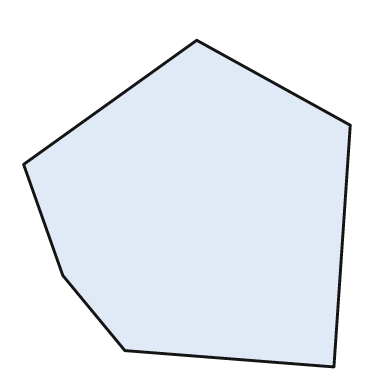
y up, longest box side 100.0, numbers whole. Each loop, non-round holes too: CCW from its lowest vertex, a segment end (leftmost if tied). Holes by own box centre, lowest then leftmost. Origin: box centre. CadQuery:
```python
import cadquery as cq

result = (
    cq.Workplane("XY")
    .moveTo(45.0, -50.0)
    .lineTo(50.0, 24.0)
    .lineTo(3.0, 50.0)
    .lineTo(-50.0, 12.0)
    .lineTo(-38.0, -22.0)
    .lineTo(-19.0, -45.0)
    .close()
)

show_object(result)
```